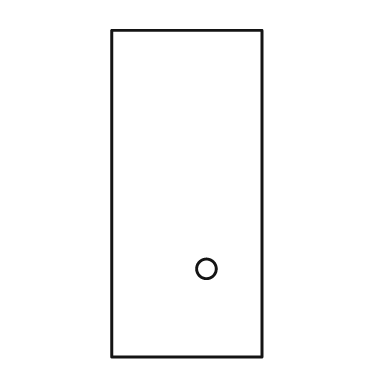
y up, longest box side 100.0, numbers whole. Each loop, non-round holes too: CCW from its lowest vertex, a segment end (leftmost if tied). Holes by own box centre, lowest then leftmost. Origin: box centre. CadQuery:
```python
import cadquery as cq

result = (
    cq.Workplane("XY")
    .moveTo(-23.0, -50.0)
    .lineTo(23.0, -50.0)
    .lineTo(23.0, 50.0)
    .lineTo(-23.0, 50.0)
    .close()
    .moveTo(6.0, -23.0)
    .circle(3.0)
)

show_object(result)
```